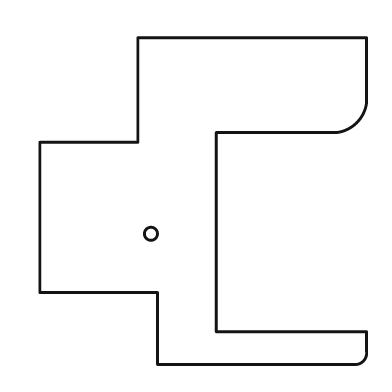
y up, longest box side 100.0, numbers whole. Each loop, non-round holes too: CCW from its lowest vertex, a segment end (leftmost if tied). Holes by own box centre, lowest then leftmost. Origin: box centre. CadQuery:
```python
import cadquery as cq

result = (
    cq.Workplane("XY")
    .moveTo(-14.0, -50.0)
    .lineTo(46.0, -50.0)
    .threePointArc((49.0, -49.0), (50.0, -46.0))
    .lineTo(50.0, -40.0)
    .lineTo(4.0, -40.0)
    .lineTo(4.0, 21.0)
    .lineTo(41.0, 21.0)
    .threePointArc((47.0, 24.0), (50.0, 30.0))
    .lineTo(50.0, 50.0)
    .lineTo(-20.0, 50.0)
    .lineTo(-20.0, 18.0)
    .lineTo(-50.0, 18.0)
    .lineTo(-50.0, -28.0)
    .lineTo(-14.0, -28.0)
    .close()
    .moveTo(-16.0, -10.0)
    .circle(2.0)
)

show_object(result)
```